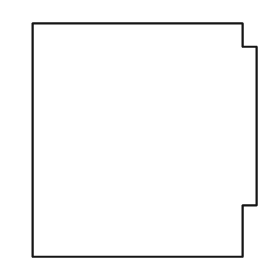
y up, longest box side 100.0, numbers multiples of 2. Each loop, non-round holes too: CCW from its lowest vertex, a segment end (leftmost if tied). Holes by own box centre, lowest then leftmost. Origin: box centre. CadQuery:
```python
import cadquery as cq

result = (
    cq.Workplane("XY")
    .moveTo(-48.0, -50.0)
    .lineTo(42.0, -50.0)
    .lineTo(42.0, -28.0)
    .lineTo(48.0, -28.0)
    .lineTo(48.0, 40.0)
    .lineTo(42.0, 40.0)
    .lineTo(42.0, 50.0)
    .lineTo(-48.0, 50.0)
    .close()
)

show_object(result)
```